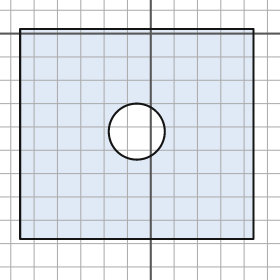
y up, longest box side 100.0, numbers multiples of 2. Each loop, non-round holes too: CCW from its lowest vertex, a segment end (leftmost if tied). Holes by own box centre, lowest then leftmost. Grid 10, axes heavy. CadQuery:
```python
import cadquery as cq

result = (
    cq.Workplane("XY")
    .moveTo(-56.0, -88.0)
    .lineTo(44.0, -88.0)
    .lineTo(44.0, 2.0)
    .lineTo(-56.0, 2.0)
    .close()
    .moveTo(-6.0, -42.0)
    .circle(12.0)
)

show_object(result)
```